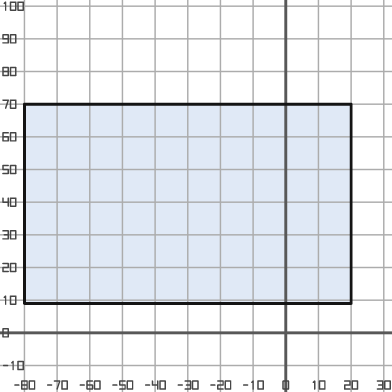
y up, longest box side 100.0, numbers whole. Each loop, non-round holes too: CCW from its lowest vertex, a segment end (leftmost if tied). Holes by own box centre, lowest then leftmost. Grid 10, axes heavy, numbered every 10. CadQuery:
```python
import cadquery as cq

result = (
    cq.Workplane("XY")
    .moveTo(-80.0, 9.0)
    .lineTo(20.0, 9.0)
    .lineTo(20.0, 70.0)
    .lineTo(-80.0, 70.0)
    .close()
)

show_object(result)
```